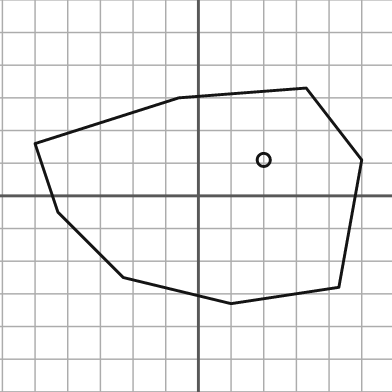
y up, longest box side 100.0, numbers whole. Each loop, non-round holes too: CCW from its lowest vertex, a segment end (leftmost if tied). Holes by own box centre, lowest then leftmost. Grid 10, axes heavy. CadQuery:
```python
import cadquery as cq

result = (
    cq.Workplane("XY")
    .moveTo(10.0, -33.0)
    .lineTo(43.0, -28.0)
    .lineTo(50.0, 11.0)
    .lineTo(33.0, 33.0)
    .lineTo(-6.0, 30.0)
    .lineTo(-50.0, 16.0)
    .lineTo(-43.0, -5.0)
    .lineTo(-23.0, -25.0)
    .close()
    .moveTo(20.0, 11.0)
    .circle(2.0)
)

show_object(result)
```